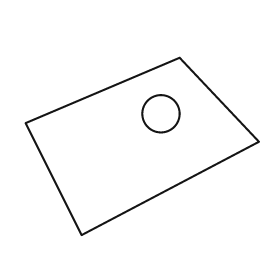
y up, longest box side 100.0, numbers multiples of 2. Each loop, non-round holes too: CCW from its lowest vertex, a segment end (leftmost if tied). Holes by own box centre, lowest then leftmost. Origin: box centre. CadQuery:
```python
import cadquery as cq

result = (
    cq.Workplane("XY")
    .moveTo(-26.0, -38.0)
    .lineTo(50.0, 2.0)
    .lineTo(16.0, 38.0)
    .lineTo(-50.0, 10.0)
    .close()
    .moveTo(8.0, 14.0)
    .circle(8.0)
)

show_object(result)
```